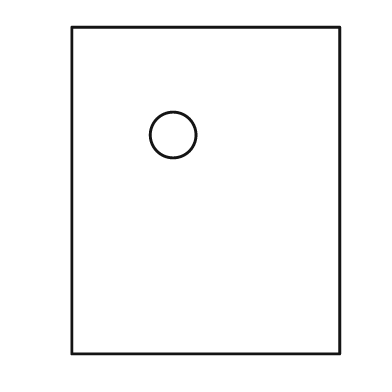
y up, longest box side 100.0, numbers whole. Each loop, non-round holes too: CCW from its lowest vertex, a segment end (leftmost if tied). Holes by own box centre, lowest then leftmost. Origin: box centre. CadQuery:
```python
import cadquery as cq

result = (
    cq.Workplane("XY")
    .moveTo(-41.0, -50.0)
    .lineTo(41.0, -50.0)
    .lineTo(41.0, 50.0)
    .lineTo(-41.0, 50.0)
    .close()
    .moveTo(-10.0, 17.0)
    .circle(7.0)
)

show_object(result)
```